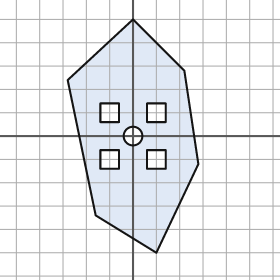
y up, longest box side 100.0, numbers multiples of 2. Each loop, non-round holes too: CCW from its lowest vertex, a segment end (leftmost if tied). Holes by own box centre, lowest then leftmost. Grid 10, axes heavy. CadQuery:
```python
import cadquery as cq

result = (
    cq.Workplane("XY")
    .moveTo(10.0, -50.0)
    .lineTo(28.0, -12.0)
    .lineTo(22.0, 28.0)
    .lineTo(0.0, 50.0)
    .lineTo(-28.0, 24.0)
    .lineTo(-16.0, -34.0)
    .close()
    .moveTo(-14.0, -14.0)
    .lineTo(-6.0, -14.0)
    .lineTo(-6.0, -6.0)
    .lineTo(-14.0, -6.0)
    .close()
    .moveTo(6.0, -14.0)
    .lineTo(14.0, -14.0)
    .lineTo(14.0, -6.0)
    .lineTo(6.0, -6.0)
    .close()
    .moveTo(0.0, 0.0)
    .circle(4.0)
    .moveTo(-14.0, 6.0)
    .lineTo(-6.0, 6.0)
    .lineTo(-6.0, 14.0)
    .lineTo(-14.0, 14.0)
    .close()
    .moveTo(6.0, 6.0)
    .lineTo(14.0, 6.0)
    .lineTo(14.0, 14.0)
    .lineTo(6.0, 14.0)
    .close()
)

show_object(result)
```